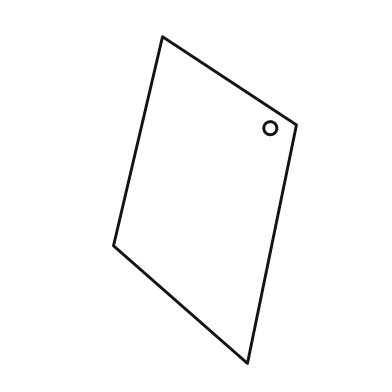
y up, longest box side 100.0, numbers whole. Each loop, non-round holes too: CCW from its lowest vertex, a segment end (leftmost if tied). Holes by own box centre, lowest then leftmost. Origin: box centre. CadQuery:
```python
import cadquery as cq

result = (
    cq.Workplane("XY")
    .moveTo(13.0, -50.0)
    .lineTo(28.0, 23.0)
    .lineTo(-13.0, 50.0)
    .lineTo(-28.0, -14.0)
    .close()
    .moveTo(20.0, 22.0)
    .circle(2.0)
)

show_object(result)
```